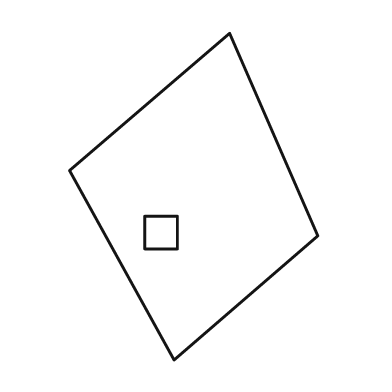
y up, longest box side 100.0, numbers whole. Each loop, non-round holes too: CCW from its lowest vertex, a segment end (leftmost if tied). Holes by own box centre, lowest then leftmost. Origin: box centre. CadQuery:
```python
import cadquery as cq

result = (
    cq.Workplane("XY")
    .moveTo(-6.0, -50.0)
    .lineTo(38.0, -12.0)
    .lineTo(11.0, 50.0)
    .lineTo(-38.0, 8.0)
    .close()
    .moveTo(-15.0, -16.0)
    .lineTo(-5.0, -16.0)
    .lineTo(-5.0, -6.0)
    .lineTo(-15.0, -6.0)
    .close()
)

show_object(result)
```